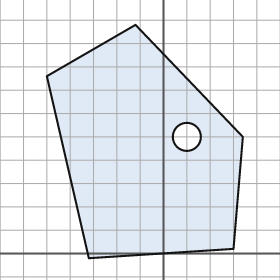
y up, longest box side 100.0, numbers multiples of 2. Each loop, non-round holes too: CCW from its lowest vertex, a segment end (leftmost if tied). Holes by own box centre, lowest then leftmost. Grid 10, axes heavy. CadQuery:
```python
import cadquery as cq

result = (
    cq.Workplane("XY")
    .moveTo(-32.0, -2.0)
    .lineTo(30.0, 2.0)
    .lineTo(34.0, 50.0)
    .lineTo(-12.0, 98.0)
    .lineTo(-50.0, 76.0)
    .close()
    .moveTo(10.0, 50.0)
    .circle(6.0)
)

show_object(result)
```